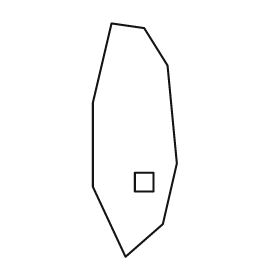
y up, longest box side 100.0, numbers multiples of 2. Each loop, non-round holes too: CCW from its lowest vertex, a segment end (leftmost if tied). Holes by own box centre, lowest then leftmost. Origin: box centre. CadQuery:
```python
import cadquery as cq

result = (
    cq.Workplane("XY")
    .moveTo(-4.0, -50.0)
    .lineTo(12.0, -36.0)
    .lineTo(18.0, -10.0)
    .lineTo(14.0, 32.0)
    .lineTo(4.0, 48.0)
    .lineTo(-10.0, 50.0)
    .lineTo(-18.0, 16.0)
    .lineTo(-18.0, -20.0)
    .close()
    .moveTo(0.0, -22.0)
    .lineTo(8.0, -22.0)
    .lineTo(8.0, -14.0)
    .lineTo(0.0, -14.0)
    .close()
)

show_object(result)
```